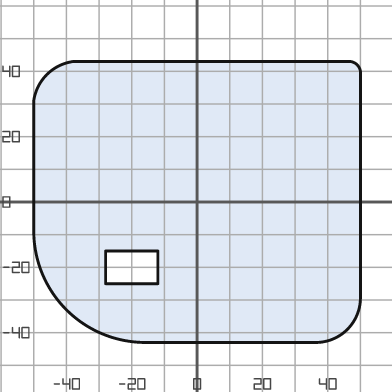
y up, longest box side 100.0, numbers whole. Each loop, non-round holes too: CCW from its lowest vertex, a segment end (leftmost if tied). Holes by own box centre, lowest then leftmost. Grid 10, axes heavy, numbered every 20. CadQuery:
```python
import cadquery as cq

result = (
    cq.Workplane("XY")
    .moveTo(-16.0, -43.0)
    .lineTo(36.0, -43.0)
    .threePointArc((46.0, -39.0), (50.0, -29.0))
    .lineTo(50.0, 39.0)
    .threePointArc((49.0, 42.0), (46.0, 43.0))
    .lineTo(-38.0, 43.0)
    .threePointArc((-46.0, 39.0), (-50.0, 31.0))
    .lineTo(-50.0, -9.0)
    .threePointArc((-40.0, -33.0), (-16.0, -43.0))
    .close()
    .moveTo(-28.0, -25.0)
    .lineTo(-12.0, -25.0)
    .lineTo(-12.0, -15.0)
    .lineTo(-28.0, -15.0)
    .close()
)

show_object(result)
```